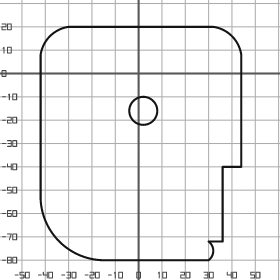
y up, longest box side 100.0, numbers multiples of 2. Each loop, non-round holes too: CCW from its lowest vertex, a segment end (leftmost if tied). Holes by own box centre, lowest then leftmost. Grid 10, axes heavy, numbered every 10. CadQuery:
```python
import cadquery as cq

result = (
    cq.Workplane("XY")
    .moveTo(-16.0, -80.0)
    .lineTo(30.0, -80.0)
    .threePointArc((32.0, -76.0), (30.0, -72.0))
    .lineTo(36.0, -72.0)
    .lineTo(36.0, -40.0)
    .lineTo(44.0, -40.0)
    .lineTo(44.0, 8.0)
    .threePointArc((40.0, 16.0), (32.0, 20.0))
    .lineTo(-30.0, 20.0)
    .threePointArc((-38.0, 16.0), (-42.0, 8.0))
    .lineTo(-42.0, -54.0)
    .threePointArc((-34.0, -72.0), (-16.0, -80.0))
    .close()
    .moveTo(2.0, -16.0)
    .circle(6.0)
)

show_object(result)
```